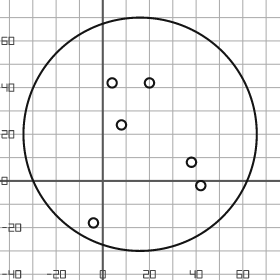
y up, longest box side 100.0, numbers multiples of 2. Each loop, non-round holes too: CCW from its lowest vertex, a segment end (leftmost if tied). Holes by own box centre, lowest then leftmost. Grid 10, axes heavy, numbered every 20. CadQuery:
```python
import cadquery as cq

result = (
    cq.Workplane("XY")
    .moveTo(16.0, 20.0)
    .circle(50.0)
    .moveTo(-4.0, -18.0)
    .circle(2.0)
    .moveTo(42.0, -2.0)
    .circle(2.0)
    .moveTo(38.0, 8.0)
    .circle(2.0)
    .moveTo(8.0, 24.0)
    .circle(2.0)
    .moveTo(4.0, 42.0)
    .circle(2.0)
    .moveTo(20.0, 42.0)
    .circle(2.0)
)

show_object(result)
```